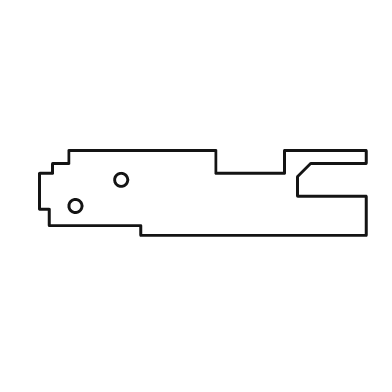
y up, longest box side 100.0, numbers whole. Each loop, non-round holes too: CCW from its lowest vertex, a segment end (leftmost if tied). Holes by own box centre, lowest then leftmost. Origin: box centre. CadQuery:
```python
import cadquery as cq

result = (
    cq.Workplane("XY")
    .moveTo(-19.0, -13.0)
    .lineTo(50.0, -13.0)
    .lineTo(50.0, -1.0)
    .lineTo(29.0, -1.0)
    .lineTo(29.0, 5.0)
    .lineTo(33.0, 9.0)
    .lineTo(50.0, 9.0)
    .lineTo(50.0, 13.0)
    .lineTo(25.0, 13.0)
    .lineTo(25.0, 6.0)
    .lineTo(4.0, 6.0)
    .lineTo(4.0, 13.0)
    .lineTo(-41.0, 13.0)
    .lineTo(-41.0, 9.0)
    .lineTo(-46.0, 9.0)
    .lineTo(-46.0, 6.0)
    .lineTo(-50.0, 6.0)
    .lineTo(-50.0, -5.0)
    .lineTo(-47.0, -5.0)
    .lineTo(-47.0, -10.0)
    .lineTo(-19.0, -10.0)
    .close()
    .moveTo(-39.0, -4.0)
    .circle(2.0)
    .moveTo(-25.0, 4.0)
    .circle(2.0)
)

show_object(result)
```